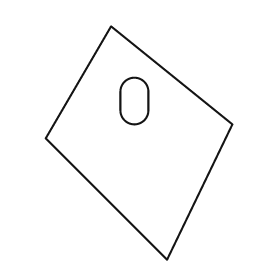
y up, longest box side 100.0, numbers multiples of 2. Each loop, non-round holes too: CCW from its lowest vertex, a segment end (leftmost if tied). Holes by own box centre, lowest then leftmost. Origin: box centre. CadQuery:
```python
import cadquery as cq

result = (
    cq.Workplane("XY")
    .moveTo(12.0, -50.0)
    .lineTo(40.0, 8.0)
    .lineTo(-12.0, 50.0)
    .lineTo(-40.0, 2.0)
    .close()
    .moveTo(-8.0, 14.0)
    .threePointArc((-2.0, 8.0), (4.0, 14.0))
    .lineTo(4.0, 22.0)
    .threePointArc((-2.0, 28.0), (-8.0, 22.0))
    .close()
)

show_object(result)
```